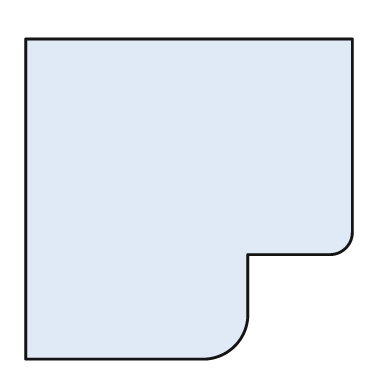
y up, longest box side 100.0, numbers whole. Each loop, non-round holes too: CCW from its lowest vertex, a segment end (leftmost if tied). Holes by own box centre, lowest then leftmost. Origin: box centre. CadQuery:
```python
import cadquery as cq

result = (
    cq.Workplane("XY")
    .moveTo(-50.0, -49.0)
    .lineTo(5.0, -49.0)
    .threePointArc((14.0, -45.0), (18.0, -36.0))
    .lineTo(18.0, -17.0)
    .lineTo(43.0, -17.0)
    .threePointArc((48.0, -15.0), (50.0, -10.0))
    .lineTo(50.0, 49.0)
    .lineTo(-50.0, 49.0)
    .close()
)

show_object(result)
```